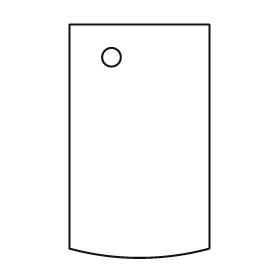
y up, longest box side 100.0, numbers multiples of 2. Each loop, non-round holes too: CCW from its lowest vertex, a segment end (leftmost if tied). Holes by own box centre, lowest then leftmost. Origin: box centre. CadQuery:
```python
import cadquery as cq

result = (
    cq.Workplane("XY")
    .moveTo(-30.0, -46.0)
    .threePointArc((0.0, -50.0), (30.0, -46.0))
    .lineTo(30.0, 50.0)
    .lineTo(-30.0, 50.0)
    .close()
    .moveTo(-12.0, 36.0)
    .circle(4.0)
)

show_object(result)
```